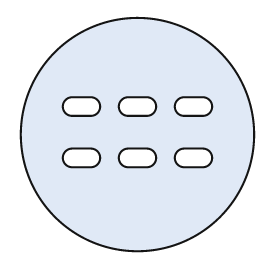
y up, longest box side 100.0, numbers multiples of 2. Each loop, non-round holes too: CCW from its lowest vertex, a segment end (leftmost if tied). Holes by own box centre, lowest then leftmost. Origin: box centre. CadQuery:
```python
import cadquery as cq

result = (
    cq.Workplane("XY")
    .moveTo(0.0, 0.0)
    .circle(50.0)
    .moveTo(-28.0, -14.0)
    .lineTo(-20.0, -14.0)
    .threePointArc((-16.0, -10.0), (-20.0, -6.0))
    .lineTo(-28.0, -6.0)
    .threePointArc((-32.0, -10.0), (-28.0, -14.0))
    .close()
    .moveTo(-4.0, -14.0)
    .lineTo(4.0, -14.0)
    .threePointArc((8.0, -10.0), (4.0, -6.0))
    .lineTo(-4.0, -6.0)
    .threePointArc((-8.0, -10.0), (-4.0, -14.0))
    .close()
    .moveTo(20.0, -14.0)
    .lineTo(28.0, -14.0)
    .threePointArc((32.0, -10.0), (28.0, -6.0))
    .lineTo(20.0, -6.0)
    .threePointArc((16.0, -10.0), (20.0, -14.0))
    .close()
    .moveTo(-28.0, 8.0)
    .lineTo(-20.0, 8.0)
    .threePointArc((-16.0, 12.0), (-20.0, 16.0))
    .lineTo(-28.0, 16.0)
    .threePointArc((-32.0, 12.0), (-28.0, 8.0))
    .close()
    .moveTo(-4.0, 8.0)
    .lineTo(4.0, 8.0)
    .threePointArc((8.0, 12.0), (4.0, 16.0))
    .lineTo(-4.0, 16.0)
    .threePointArc((-8.0, 12.0), (-4.0, 8.0))
    .close()
    .moveTo(20.0, 8.0)
    .lineTo(28.0, 8.0)
    .threePointArc((32.0, 12.0), (28.0, 16.0))
    .lineTo(20.0, 16.0)
    .threePointArc((16.0, 12.0), (20.0, 8.0))
    .close()
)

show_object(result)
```